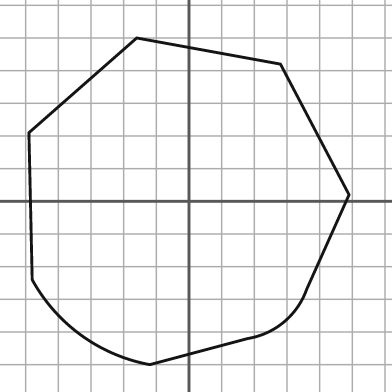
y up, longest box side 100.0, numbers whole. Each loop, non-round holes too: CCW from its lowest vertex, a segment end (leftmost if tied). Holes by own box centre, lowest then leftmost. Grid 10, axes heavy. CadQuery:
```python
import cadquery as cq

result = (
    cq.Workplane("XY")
    .moveTo(-12.0, -50.0)
    .lineTo(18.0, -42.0)
    .threePointArc((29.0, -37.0), (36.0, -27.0))
    .lineTo(49.0, 2.0)
    .lineTo(28.0, 42.0)
    .lineTo(-16.0, 50.0)
    .lineTo(-49.0, 21.0)
    .lineTo(-48.0, -24.0)
    .threePointArc((-33.0, -41.0), (-12.0, -50.0))
    .close()
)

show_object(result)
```